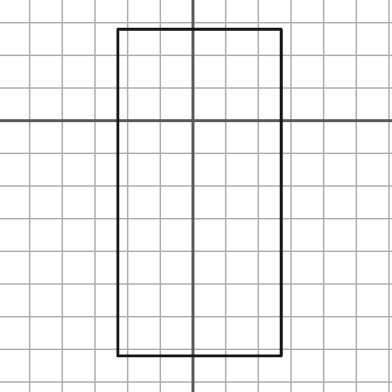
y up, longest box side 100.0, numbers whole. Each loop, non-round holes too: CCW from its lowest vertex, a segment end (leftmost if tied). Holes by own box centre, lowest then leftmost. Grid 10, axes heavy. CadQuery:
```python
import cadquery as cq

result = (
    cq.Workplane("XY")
    .moveTo(-23.0, -72.0)
    .lineTo(27.0, -72.0)
    .lineTo(27.0, 28.0)
    .lineTo(-23.0, 28.0)
    .close()
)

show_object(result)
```